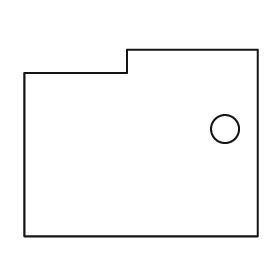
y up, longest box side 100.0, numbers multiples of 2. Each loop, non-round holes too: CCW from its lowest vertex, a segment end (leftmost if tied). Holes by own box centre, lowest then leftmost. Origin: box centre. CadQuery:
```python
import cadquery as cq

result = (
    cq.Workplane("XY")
    .moveTo(-50.0, -40.0)
    .lineTo(50.0, -40.0)
    .lineTo(50.0, 40.0)
    .lineTo(-6.0, 40.0)
    .lineTo(-6.0, 30.0)
    .lineTo(-50.0, 30.0)
    .close()
    .moveTo(36.0, 6.0)
    .circle(6.0)
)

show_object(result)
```